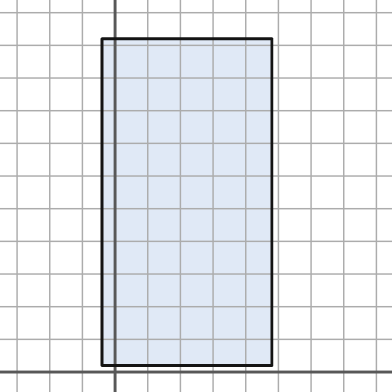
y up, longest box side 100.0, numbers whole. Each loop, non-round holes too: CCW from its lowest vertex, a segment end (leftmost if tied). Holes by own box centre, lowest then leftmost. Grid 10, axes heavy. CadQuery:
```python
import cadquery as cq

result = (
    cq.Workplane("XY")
    .moveTo(-4.0, 2.0)
    .lineTo(48.0, 2.0)
    .lineTo(48.0, 102.0)
    .lineTo(-4.0, 102.0)
    .close()
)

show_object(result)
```